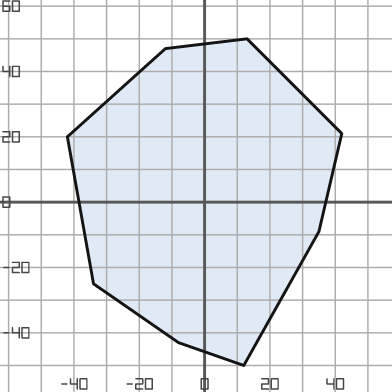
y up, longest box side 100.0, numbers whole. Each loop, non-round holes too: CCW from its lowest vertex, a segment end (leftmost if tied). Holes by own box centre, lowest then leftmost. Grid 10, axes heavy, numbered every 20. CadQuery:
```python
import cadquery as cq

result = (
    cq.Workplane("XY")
    .moveTo(12.0, -50.0)
    .lineTo(35.0, -9.0)
    .lineTo(42.0, 21.0)
    .lineTo(13.0, 50.0)
    .lineTo(-12.0, 47.0)
    .lineTo(-42.0, 20.0)
    .lineTo(-34.0, -25.0)
    .lineTo(-8.0, -43.0)
    .close()
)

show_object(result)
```